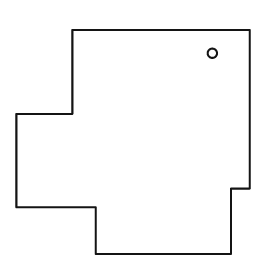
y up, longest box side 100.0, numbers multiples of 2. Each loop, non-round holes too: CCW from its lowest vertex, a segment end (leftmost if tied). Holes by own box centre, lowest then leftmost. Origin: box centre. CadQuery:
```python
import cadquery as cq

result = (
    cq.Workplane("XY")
    .moveTo(-16.0, -48.0)
    .lineTo(42.0, -48.0)
    .lineTo(42.0, -20.0)
    .lineTo(50.0, -20.0)
    .lineTo(50.0, 48.0)
    .lineTo(-26.0, 48.0)
    .lineTo(-26.0, 12.0)
    .lineTo(-50.0, 12.0)
    .lineTo(-50.0, -28.0)
    .lineTo(-16.0, -28.0)
    .close()
    .moveTo(34.0, 38.0)
    .circle(2.0)
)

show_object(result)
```